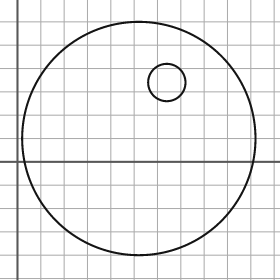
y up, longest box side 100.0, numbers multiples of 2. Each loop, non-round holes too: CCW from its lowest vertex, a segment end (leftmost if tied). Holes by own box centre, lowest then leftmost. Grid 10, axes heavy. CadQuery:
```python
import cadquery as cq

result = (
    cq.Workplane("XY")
    .moveTo(52.0, 10.0)
    .circle(50.0)
    .moveTo(64.0, 34.0)
    .circle(8.0)
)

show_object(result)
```